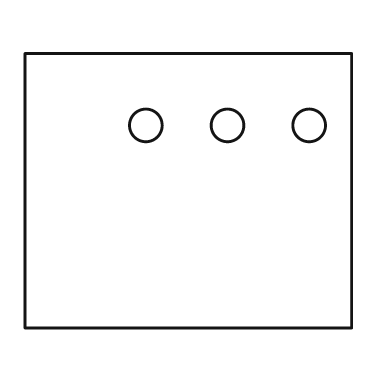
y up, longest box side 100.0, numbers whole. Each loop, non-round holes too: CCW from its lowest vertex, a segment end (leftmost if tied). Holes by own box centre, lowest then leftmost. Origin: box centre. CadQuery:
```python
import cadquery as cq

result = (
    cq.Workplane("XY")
    .moveTo(-50.0, -42.0)
    .lineTo(50.0, -42.0)
    .lineTo(50.0, 42.0)
    .lineTo(-50.0, 42.0)
    .close()
    .moveTo(-13.0, 20.0)
    .circle(5.0)
    .moveTo(12.0, 20.0)
    .circle(5.0)
    .moveTo(37.0, 20.0)
    .circle(5.0)
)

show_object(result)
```